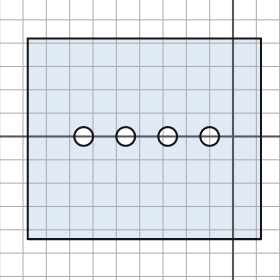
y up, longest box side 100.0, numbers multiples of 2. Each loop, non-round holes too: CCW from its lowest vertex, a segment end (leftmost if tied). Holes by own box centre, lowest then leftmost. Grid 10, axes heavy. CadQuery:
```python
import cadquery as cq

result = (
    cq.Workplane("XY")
    .moveTo(-88.0, -44.0)
    .lineTo(12.0, -44.0)
    .lineTo(12.0, 42.0)
    .lineTo(-88.0, 42.0)
    .close()
    .moveTo(-64.0, 0.0)
    .circle(4.0)
    .moveTo(-46.0, 0.0)
    .circle(4.0)
    .moveTo(-28.0, 0.0)
    .circle(4.0)
    .moveTo(-10.0, 0.0)
    .circle(4.0)
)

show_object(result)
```